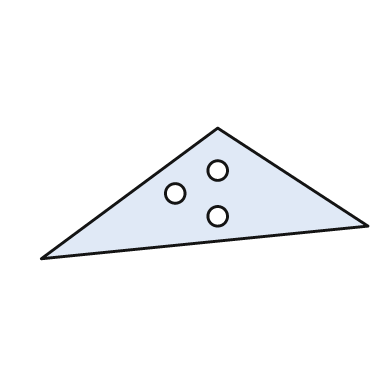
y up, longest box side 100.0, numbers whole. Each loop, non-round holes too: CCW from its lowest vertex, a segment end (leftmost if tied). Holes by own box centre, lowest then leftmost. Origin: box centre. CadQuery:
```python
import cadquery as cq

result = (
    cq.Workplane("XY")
    .moveTo(-50.0, -20.0)
    .lineTo(50.0, -10.0)
    .lineTo(4.0, 20.0)
    .close()
    .moveTo(4.0, -7.0)
    .circle(3.0)
    .moveTo(-9.0, 0.0)
    .circle(3.0)
    .moveTo(4.0, 7.0)
    .circle(3.0)
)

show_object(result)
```